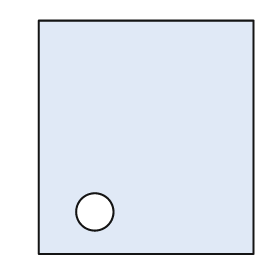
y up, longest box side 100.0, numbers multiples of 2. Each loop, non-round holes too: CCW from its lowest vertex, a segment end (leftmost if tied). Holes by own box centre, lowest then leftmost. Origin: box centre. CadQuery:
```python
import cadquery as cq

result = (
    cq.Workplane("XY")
    .moveTo(-46.0, -50.0)
    .lineTo(46.0, -50.0)
    .lineTo(46.0, 50.0)
    .lineTo(-46.0, 50.0)
    .close()
    .moveTo(-22.0, -32.0)
    .circle(8.0)
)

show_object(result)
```